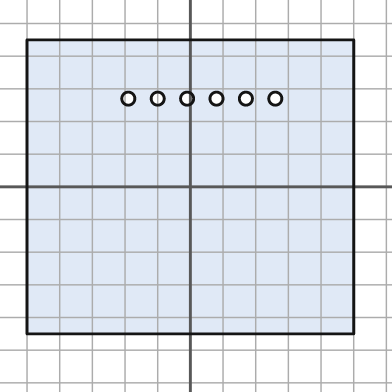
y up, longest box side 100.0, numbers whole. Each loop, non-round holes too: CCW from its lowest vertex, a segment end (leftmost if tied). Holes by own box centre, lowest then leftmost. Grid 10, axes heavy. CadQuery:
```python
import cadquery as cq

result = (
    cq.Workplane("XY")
    .moveTo(-50.0, -45.0)
    .lineTo(50.0, -45.0)
    .lineTo(50.0, 45.0)
    .lineTo(-50.0, 45.0)
    .close()
    .moveTo(-19.0, 27.0)
    .circle(2.0)
    .moveTo(-10.0, 27.0)
    .circle(2.0)
    .moveTo(-1.0, 27.0)
    .circle(2.0)
    .moveTo(8.0, 27.0)
    .circle(2.0)
    .moveTo(17.0, 27.0)
    .circle(2.0)
    .moveTo(26.0, 27.0)
    .circle(2.0)
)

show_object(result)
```